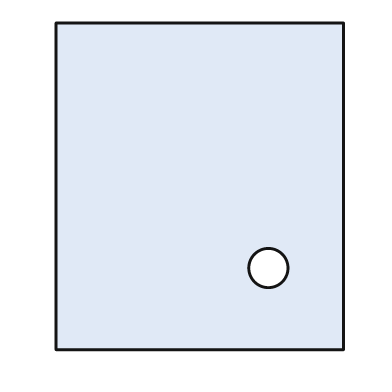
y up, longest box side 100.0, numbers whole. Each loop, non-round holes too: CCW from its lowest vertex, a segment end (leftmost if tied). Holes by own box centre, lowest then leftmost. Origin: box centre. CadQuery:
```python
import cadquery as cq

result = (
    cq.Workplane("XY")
    .moveTo(-44.0, -50.0)
    .lineTo(44.0, -50.0)
    .lineTo(44.0, 50.0)
    .lineTo(-44.0, 50.0)
    .close()
    .moveTo(21.0, -25.0)
    .circle(6.0)
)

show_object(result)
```